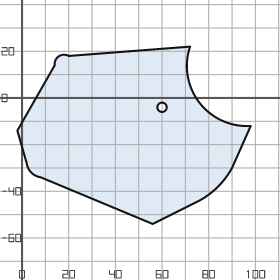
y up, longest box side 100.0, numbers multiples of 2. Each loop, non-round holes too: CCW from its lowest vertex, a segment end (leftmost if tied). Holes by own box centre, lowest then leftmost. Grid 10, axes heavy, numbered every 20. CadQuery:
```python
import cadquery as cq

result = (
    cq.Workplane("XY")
    .moveTo(56.0, -54.0)
    .lineTo(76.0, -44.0)
    .threePointArc((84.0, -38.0), (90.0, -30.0))
    .lineTo(98.0, -12.0)
    .threePointArc((76.0, -2.0), (72.0, 22.0))
    .lineTo(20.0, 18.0)
    .threePointArc((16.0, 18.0), (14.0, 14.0))
    .lineTo(-2.0, -14.0)
    .lineTo(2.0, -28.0)
    .threePointArc((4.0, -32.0), (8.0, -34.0))
    .close()
    .moveTo(60.0, -4.0)
    .circle(2.0)
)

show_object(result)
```